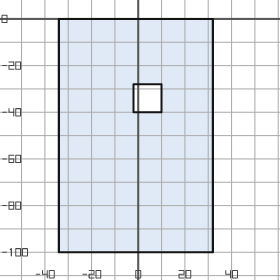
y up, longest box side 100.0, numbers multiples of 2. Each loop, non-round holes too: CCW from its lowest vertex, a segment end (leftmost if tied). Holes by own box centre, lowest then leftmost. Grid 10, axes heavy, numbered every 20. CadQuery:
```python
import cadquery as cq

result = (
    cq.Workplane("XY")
    .moveTo(-34.0, -100.0)
    .lineTo(32.0, -100.0)
    .lineTo(32.0, 0.0)
    .lineTo(-34.0, 0.0)
    .close()
    .moveTo(-2.0, -40.0)
    .lineTo(10.0, -40.0)
    .lineTo(10.0, -28.0)
    .lineTo(-2.0, -28.0)
    .close()
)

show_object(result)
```